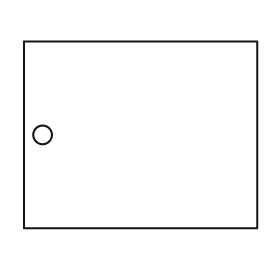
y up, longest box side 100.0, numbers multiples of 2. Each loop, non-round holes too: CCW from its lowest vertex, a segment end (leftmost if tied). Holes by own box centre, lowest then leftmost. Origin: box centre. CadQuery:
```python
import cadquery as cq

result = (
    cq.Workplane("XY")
    .moveTo(-50.0, -40.0)
    .lineTo(50.0, -40.0)
    .lineTo(50.0, 40.0)
    .lineTo(-50.0, 40.0)
    .close()
    .moveTo(-42.0, 0.0)
    .circle(4.0)
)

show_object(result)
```